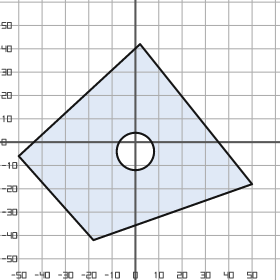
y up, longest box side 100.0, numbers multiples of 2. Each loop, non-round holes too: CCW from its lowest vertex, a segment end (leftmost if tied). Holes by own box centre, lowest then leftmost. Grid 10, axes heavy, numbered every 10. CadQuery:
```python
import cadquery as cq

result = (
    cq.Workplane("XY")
    .moveTo(-18.0, -42.0)
    .lineTo(50.0, -18.0)
    .lineTo(2.0, 42.0)
    .lineTo(-50.0, -6.0)
    .close()
    .moveTo(0.0, -4.0)
    .circle(8.0)
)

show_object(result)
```